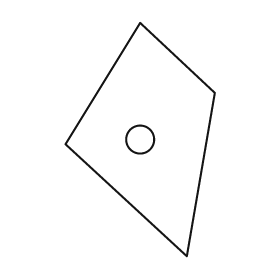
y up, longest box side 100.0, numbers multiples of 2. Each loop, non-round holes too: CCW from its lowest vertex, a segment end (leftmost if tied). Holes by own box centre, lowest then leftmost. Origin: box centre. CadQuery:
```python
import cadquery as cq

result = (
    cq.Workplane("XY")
    .moveTo(20.0, -50.0)
    .lineTo(32.0, 20.0)
    .lineTo(0.0, 50.0)
    .lineTo(-32.0, -2.0)
    .close()
    .moveTo(0.0, 0.0)
    .circle(6.0)
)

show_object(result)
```